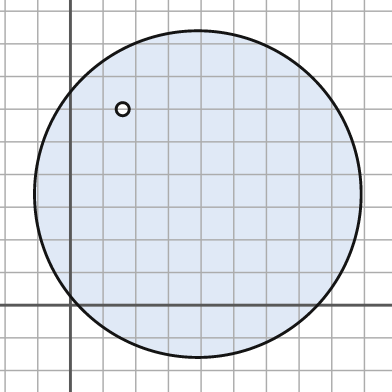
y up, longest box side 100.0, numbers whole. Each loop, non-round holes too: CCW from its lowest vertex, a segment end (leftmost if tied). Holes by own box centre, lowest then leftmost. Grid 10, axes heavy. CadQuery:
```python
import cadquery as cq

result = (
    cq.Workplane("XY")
    .moveTo(39.0, 34.0)
    .circle(50.0)
    .moveTo(16.0, 60.0)
    .circle(2.0)
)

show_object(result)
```